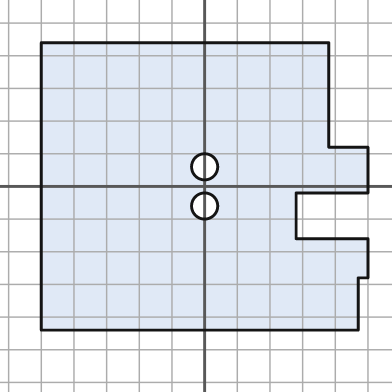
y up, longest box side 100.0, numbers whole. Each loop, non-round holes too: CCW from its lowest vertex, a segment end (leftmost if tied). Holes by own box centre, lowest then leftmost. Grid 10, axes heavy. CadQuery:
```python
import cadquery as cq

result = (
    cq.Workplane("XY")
    .moveTo(-50.0, -44.0)
    .lineTo(47.0, -44.0)
    .lineTo(47.0, -28.0)
    .lineTo(50.0, -28.0)
    .lineTo(50.0, -16.0)
    .lineTo(28.0, -16.0)
    .lineTo(28.0, -2.0)
    .lineTo(50.0, -2.0)
    .lineTo(50.0, 12.0)
    .lineTo(38.0, 12.0)
    .lineTo(38.0, 44.0)
    .lineTo(-50.0, 44.0)
    .close()
    .moveTo(0.0, -6.0)
    .circle(4.0)
    .moveTo(0.0, 6.0)
    .circle(4.0)
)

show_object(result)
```